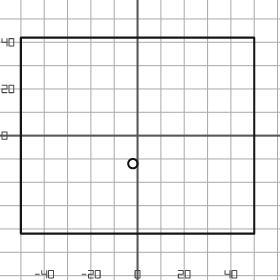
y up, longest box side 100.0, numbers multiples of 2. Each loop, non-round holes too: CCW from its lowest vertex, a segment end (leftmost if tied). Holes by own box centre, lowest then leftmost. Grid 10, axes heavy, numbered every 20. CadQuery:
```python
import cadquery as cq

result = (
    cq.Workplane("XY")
    .moveTo(-50.0, -42.0)
    .lineTo(50.0, -42.0)
    .lineTo(50.0, 42.0)
    .lineTo(-50.0, 42.0)
    .close()
    .moveTo(-2.0, -12.0)
    .circle(2.0)
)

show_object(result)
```